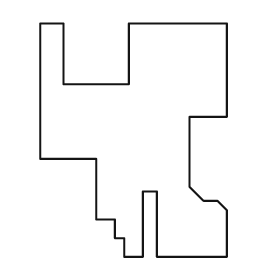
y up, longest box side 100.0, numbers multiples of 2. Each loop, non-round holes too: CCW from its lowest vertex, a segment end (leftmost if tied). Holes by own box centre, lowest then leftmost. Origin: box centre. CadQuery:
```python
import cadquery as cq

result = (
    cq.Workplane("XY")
    .moveTo(-4.0, -50.0)
    .lineTo(4.0, -50.0)
    .lineTo(4.0, -22.0)
    .lineTo(10.0, -22.0)
    .lineTo(10.0, -50.0)
    .lineTo(40.0, -50.0)
    .lineTo(40.0, -30.0)
    .lineTo(36.0, -26.0)
    .lineTo(30.0, -26.0)
    .lineTo(24.0, -20.0)
    .lineTo(24.0, 10.0)
    .lineTo(40.0, 10.0)
    .lineTo(40.0, 50.0)
    .lineTo(-2.0, 50.0)
    .lineTo(-2.0, 24.0)
    .lineTo(-30.0, 24.0)
    .lineTo(-30.0, 50.0)
    .lineTo(-40.0, 50.0)
    .lineTo(-40.0, -8.0)
    .lineTo(-16.0, -8.0)
    .lineTo(-16.0, -34.0)
    .lineTo(-8.0, -34.0)
    .lineTo(-8.0, -42.0)
    .lineTo(-4.0, -42.0)
    .close()
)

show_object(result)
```